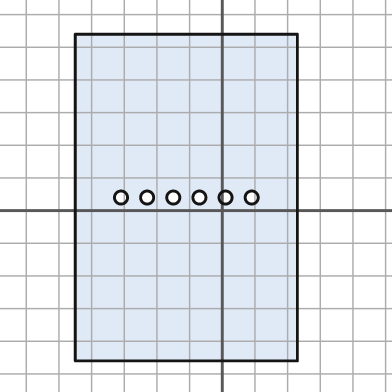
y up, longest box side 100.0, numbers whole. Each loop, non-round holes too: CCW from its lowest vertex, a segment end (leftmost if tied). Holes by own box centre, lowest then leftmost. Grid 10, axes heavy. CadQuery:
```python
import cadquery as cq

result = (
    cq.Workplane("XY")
    .moveTo(-45.0, -46.0)
    .lineTo(23.0, -46.0)
    .lineTo(23.0, 54.0)
    .lineTo(-45.0, 54.0)
    .close()
    .moveTo(-31.0, 4.0)
    .circle(2.0)
    .moveTo(-23.0, 4.0)
    .circle(2.0)
    .moveTo(-15.0, 4.0)
    .circle(2.0)
    .moveTo(-7.0, 4.0)
    .circle(2.0)
    .moveTo(1.0, 4.0)
    .circle(2.0)
    .moveTo(9.0, 4.0)
    .circle(2.0)
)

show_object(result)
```